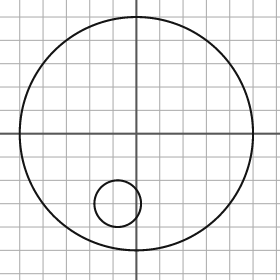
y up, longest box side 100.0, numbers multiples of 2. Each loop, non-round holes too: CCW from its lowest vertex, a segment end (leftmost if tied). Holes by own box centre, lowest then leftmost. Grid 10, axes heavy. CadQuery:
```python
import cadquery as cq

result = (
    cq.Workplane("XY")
    .moveTo(0.0, 0.0)
    .circle(50.0)
    .moveTo(-8.0, -30.0)
    .circle(10.0)
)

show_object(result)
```